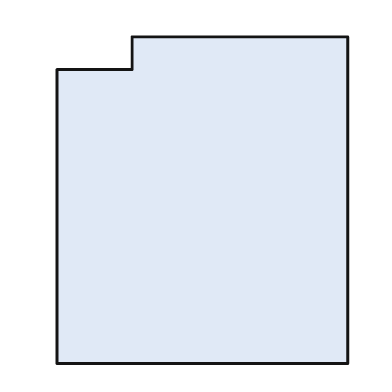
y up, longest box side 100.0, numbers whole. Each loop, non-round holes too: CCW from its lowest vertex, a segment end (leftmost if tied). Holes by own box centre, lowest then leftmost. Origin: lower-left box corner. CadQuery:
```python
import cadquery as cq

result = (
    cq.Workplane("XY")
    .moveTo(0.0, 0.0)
    .lineTo(89.0, 0.0)
    .lineTo(89.0, 100.0)
    .lineTo(23.0, 100.0)
    .lineTo(23.0, 90.0)
    .lineTo(0.0, 90.0)
    .close()
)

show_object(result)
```